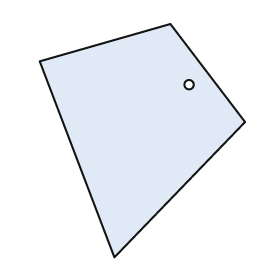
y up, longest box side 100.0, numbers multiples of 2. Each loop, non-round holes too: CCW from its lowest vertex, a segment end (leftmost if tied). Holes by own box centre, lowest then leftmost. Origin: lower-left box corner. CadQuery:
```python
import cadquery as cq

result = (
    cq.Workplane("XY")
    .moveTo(32.0, 0.0)
    .lineTo(88.0, 58.0)
    .lineTo(56.0, 100.0)
    .lineTo(0.0, 84.0)
    .close()
    .moveTo(64.0, 74.0)
    .circle(2.0)
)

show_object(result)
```